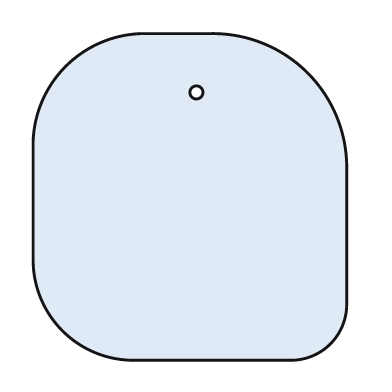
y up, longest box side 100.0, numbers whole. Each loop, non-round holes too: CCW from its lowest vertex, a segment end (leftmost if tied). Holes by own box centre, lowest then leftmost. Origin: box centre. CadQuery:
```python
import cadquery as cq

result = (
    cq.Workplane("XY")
    .moveTo(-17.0, -50.0)
    .lineTo(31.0, -50.0)
    .threePointArc((43.0, -45.0), (48.0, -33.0))
    .lineTo(48.0, 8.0)
    .threePointArc((36.0, 38.0), (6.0, 50.0))
    .lineTo(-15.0, 50.0)
    .threePointArc((-38.0, 40.0), (-48.0, 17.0))
    .lineTo(-48.0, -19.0)
    .threePointArc((-39.0, -41.0), (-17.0, -50.0))
    .close()
    .moveTo(2.0, 32.0)
    .circle(2.0)
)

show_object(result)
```